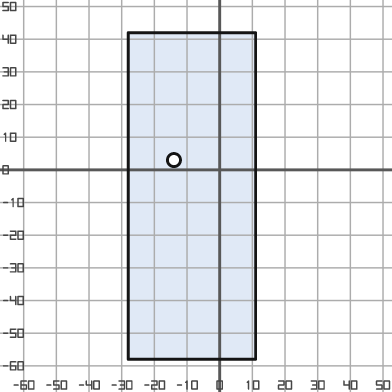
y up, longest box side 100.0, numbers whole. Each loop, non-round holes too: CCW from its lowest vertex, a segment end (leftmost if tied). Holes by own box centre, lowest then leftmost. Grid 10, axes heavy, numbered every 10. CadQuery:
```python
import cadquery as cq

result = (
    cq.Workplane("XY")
    .moveTo(-28.0, -58.0)
    .lineTo(11.0, -58.0)
    .lineTo(11.0, 42.0)
    .lineTo(-28.0, 42.0)
    .close()
    .moveTo(-14.0, 3.0)
    .circle(2.0)
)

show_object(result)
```